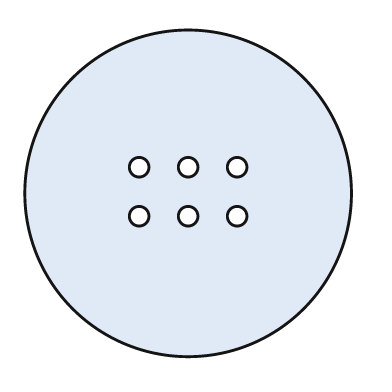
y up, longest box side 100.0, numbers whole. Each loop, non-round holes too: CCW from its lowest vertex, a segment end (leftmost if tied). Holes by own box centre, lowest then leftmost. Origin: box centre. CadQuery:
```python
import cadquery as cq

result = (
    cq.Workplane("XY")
    .moveTo(0.0, 0.0)
    .circle(50.0)
    .moveTo(-15.0, -7.0)
    .circle(3.0)
    .moveTo(0.0, -7.0)
    .circle(3.0)
    .moveTo(15.0, -7.0)
    .circle(3.0)
    .moveTo(-15.0, 8.0)
    .circle(3.0)
    .moveTo(0.0, 8.0)
    .circle(3.0)
    .moveTo(15.0, 8.0)
    .circle(3.0)
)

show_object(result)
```